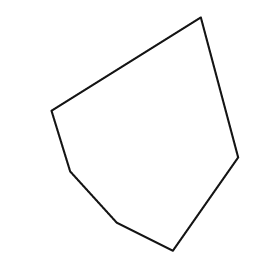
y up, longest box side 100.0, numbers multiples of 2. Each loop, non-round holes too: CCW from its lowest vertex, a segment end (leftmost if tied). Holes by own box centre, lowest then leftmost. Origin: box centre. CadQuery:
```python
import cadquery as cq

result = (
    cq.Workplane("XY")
    .moveTo(12.0, -50.0)
    .lineTo(40.0, -10.0)
    .lineTo(24.0, 50.0)
    .lineTo(-40.0, 10.0)
    .lineTo(-32.0, -16.0)
    .lineTo(-12.0, -38.0)
    .close()
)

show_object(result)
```